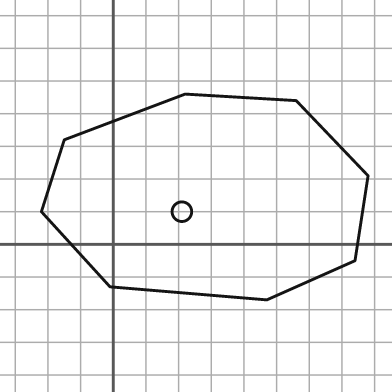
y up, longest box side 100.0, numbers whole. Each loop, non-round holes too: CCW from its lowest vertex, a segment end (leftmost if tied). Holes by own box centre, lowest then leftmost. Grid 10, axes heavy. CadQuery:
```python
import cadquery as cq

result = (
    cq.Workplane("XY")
    .moveTo(47.0, -17.0)
    .lineTo(74.0, -5.0)
    .lineTo(78.0, 21.0)
    .lineTo(56.0, 44.0)
    .lineTo(22.0, 46.0)
    .lineTo(-15.0, 32.0)
    .lineTo(-22.0, 10.0)
    .lineTo(-1.0, -13.0)
    .close()
    .moveTo(21.0, 10.0)
    .circle(3.0)
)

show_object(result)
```